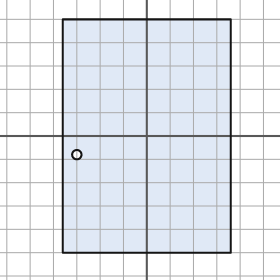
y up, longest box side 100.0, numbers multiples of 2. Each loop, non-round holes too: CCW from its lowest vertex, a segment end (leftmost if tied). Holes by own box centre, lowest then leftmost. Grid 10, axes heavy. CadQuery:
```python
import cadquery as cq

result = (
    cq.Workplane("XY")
    .moveTo(-36.0, -50.0)
    .lineTo(36.0, -50.0)
    .lineTo(36.0, 50.0)
    .lineTo(-36.0, 50.0)
    .close()
    .moveTo(-30.0, -8.0)
    .circle(2.0)
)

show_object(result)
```